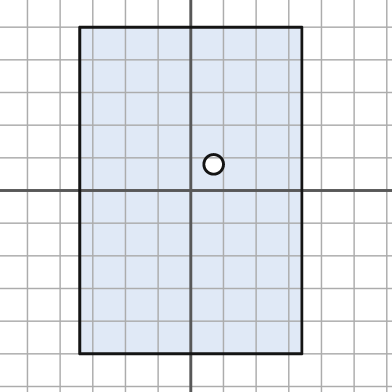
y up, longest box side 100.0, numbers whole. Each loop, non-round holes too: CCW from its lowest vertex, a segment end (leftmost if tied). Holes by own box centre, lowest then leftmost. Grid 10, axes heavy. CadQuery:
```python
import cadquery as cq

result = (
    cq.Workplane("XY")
    .moveTo(-34.0, -50.0)
    .lineTo(34.0, -50.0)
    .lineTo(34.0, 50.0)
    .lineTo(-34.0, 50.0)
    .close()
    .moveTo(7.0, 8.0)
    .circle(3.0)
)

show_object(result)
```